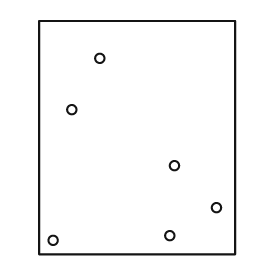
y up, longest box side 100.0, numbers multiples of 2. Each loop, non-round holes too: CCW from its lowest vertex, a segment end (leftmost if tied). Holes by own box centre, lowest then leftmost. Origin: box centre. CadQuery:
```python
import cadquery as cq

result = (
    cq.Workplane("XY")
    .moveTo(-42.0, -50.0)
    .lineTo(42.0, -50.0)
    .lineTo(42.0, 50.0)
    .lineTo(-42.0, 50.0)
    .close()
    .moveTo(-36.0, -44.0)
    .circle(2.0)
    .moveTo(14.0, -42.0)
    .circle(2.0)
    .moveTo(34.0, -30.0)
    .circle(2.0)
    .moveTo(16.0, -12.0)
    .circle(2.0)
    .moveTo(-28.0, 12.0)
    .circle(2.0)
    .moveTo(-16.0, 34.0)
    .circle(2.0)
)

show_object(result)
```